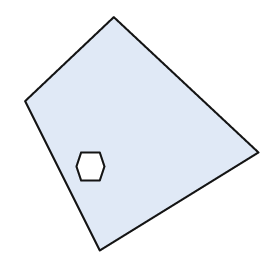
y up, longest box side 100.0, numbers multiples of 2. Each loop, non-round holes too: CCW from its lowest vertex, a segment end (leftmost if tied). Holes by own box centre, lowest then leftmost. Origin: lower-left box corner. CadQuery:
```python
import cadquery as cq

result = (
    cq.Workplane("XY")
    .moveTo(32.0, 0.0)
    .lineTo(100.0, 42.0)
    .lineTo(38.0, 100.0)
    .lineTo(0.0, 64.0)
    .close()
    .moveTo(24.0, 30.0)
    .lineTo(32.0, 30.0)
    .lineTo(34.0, 36.0)
    .lineTo(32.0, 42.0)
    .lineTo(24.0, 42.0)
    .lineTo(22.0, 36.0)
    .close()
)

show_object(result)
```